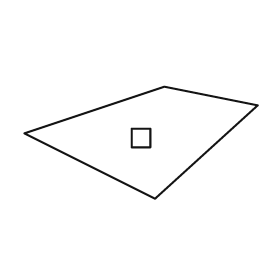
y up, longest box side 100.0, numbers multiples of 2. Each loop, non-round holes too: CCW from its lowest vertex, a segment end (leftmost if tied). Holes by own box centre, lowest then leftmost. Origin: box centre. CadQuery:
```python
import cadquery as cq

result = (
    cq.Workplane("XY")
    .moveTo(6.0, -24.0)
    .lineTo(50.0, 16.0)
    .lineTo(10.0, 24.0)
    .lineTo(-50.0, 4.0)
    .close()
    .moveTo(-4.0, -2.0)
    .lineTo(4.0, -2.0)
    .lineTo(4.0, 6.0)
    .lineTo(-4.0, 6.0)
    .close()
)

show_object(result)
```